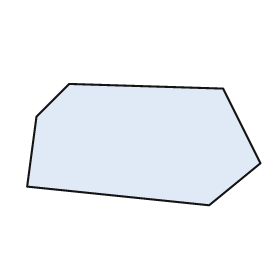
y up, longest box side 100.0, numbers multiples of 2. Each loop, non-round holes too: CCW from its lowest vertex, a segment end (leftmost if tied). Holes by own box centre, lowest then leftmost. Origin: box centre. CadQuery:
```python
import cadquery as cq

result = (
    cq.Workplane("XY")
    .moveTo(28.0, -26.0)
    .lineTo(50.0, -8.0)
    .lineTo(34.0, 24.0)
    .lineTo(-32.0, 26.0)
    .lineTo(-46.0, 12.0)
    .lineTo(-50.0, -18.0)
    .close()
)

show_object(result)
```